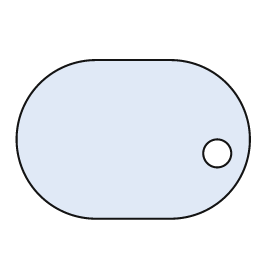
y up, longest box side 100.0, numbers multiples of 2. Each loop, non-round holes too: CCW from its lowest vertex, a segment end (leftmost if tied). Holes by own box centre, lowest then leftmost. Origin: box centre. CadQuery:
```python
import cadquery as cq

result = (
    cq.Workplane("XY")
    .moveTo(-16.0, -34.0)
    .lineTo(16.0, -34.0)
    .threePointArc((50.0, 0.0), (16.0, 34.0))
    .lineTo(-16.0, 34.0)
    .threePointArc((-50.0, 0.0), (-16.0, -34.0))
    .close()
    .moveTo(36.0, -6.0)
    .circle(6.0)
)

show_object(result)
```